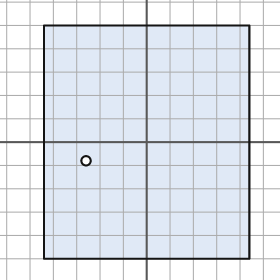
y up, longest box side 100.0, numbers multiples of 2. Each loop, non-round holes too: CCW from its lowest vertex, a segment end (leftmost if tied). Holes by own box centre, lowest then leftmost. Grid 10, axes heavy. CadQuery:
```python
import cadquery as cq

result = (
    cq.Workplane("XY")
    .moveTo(-44.0, -50.0)
    .lineTo(44.0, -50.0)
    .lineTo(44.0, 50.0)
    .lineTo(-44.0, 50.0)
    .close()
    .moveTo(-26.0, -8.0)
    .circle(2.0)
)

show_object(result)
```